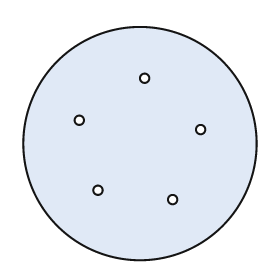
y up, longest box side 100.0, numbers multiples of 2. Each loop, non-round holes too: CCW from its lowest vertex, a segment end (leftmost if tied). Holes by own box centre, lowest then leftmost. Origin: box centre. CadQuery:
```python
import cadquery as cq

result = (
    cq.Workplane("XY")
    .moveTo(0.0, 0.0)
    .circle(50.0)
    .moveTo(14.0, -24.0)
    .circle(2.0)
    .moveTo(-18.0, -20.0)
    .circle(2.0)
    .moveTo(26.0, 6.0)
    .circle(2.0)
    .moveTo(-26.0, 10.0)
    .circle(2.0)
    .moveTo(2.0, 28.0)
    .circle(2.0)
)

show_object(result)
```